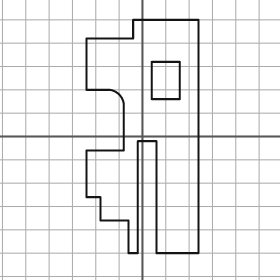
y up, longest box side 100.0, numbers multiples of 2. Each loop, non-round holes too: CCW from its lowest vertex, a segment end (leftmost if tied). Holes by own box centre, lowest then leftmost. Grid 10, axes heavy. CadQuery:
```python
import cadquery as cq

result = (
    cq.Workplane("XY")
    .moveTo(-6.0, -50.0)
    .lineTo(-2.0, -50.0)
    .lineTo(-2.0, -2.0)
    .lineTo(6.0, -2.0)
    .lineTo(6.0, -50.0)
    .lineTo(24.0, -50.0)
    .lineTo(24.0, 50.0)
    .lineTo(-4.0, 50.0)
    .lineTo(-4.0, 42.0)
    .lineTo(-24.0, 42.0)
    .lineTo(-24.0, 20.0)
    .lineTo(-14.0, 20.0)
    .threePointArc((-10.0, 18.0), (-8.0, 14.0))
    .lineTo(-8.0, -6.0)
    .lineTo(-24.0, -6.0)
    .lineTo(-24.0, -26.0)
    .lineTo(-18.0, -26.0)
    .lineTo(-18.0, -36.0)
    .lineTo(-6.0, -36.0)
    .close()
    .moveTo(4.0, 16.0)
    .lineTo(16.0, 16.0)
    .lineTo(16.0, 32.0)
    .lineTo(4.0, 32.0)
    .close()
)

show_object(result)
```